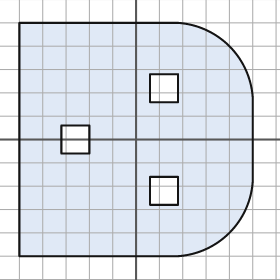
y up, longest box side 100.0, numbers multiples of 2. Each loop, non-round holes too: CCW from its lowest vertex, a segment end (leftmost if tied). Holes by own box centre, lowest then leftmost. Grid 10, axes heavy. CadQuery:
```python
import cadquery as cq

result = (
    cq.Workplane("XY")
    .moveTo(-50.0, -50.0)
    .lineTo(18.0, -50.0)
    .threePointArc((40.0, -40.0), (50.0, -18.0))
    .lineTo(50.0, 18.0)
    .threePointArc((40.0, 40.0), (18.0, 50.0))
    .lineTo(-50.0, 50.0)
    .close()
    .moveTo(6.0, -28.0)
    .lineTo(18.0, -28.0)
    .lineTo(18.0, -16.0)
    .lineTo(6.0, -16.0)
    .close()
    .moveTo(-32.0, -6.0)
    .lineTo(-20.0, -6.0)
    .lineTo(-20.0, 6.0)
    .lineTo(-32.0, 6.0)
    .close()
    .moveTo(6.0, 16.0)
    .lineTo(18.0, 16.0)
    .lineTo(18.0, 28.0)
    .lineTo(6.0, 28.0)
    .close()
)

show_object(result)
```